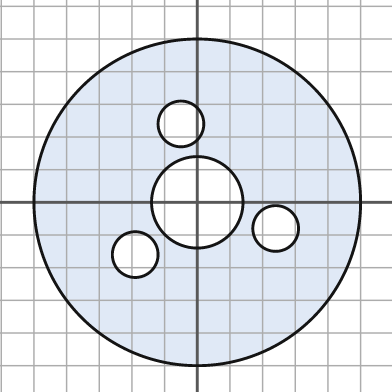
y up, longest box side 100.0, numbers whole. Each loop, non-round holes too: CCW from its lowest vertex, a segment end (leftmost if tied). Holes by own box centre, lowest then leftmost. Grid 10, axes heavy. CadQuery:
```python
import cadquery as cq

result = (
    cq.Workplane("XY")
    .moveTo(0.0, 0.0)
    .circle(50.0)
    .moveTo(-19.0, -16.0)
    .circle(7.0)
    .moveTo(24.0, -8.0)
    .circle(7.0)
    .moveTo(0.0, 0.0)
    .circle(14.0)
    .moveTo(-5.0, 24.0)
    .circle(7.0)
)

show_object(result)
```